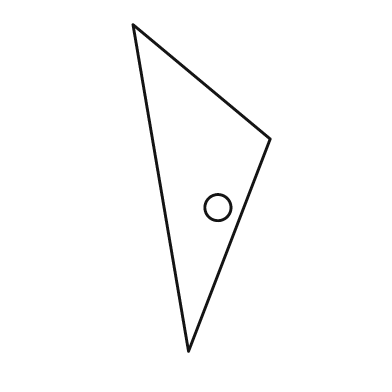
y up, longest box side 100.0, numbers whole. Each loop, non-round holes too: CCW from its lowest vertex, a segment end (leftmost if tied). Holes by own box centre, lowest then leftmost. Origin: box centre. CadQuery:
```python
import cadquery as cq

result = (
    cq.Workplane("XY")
    .moveTo(-4.0, -50.0)
    .lineTo(21.0, 15.0)
    .lineTo(-21.0, 50.0)
    .close()
    .moveTo(5.0, -6.0)
    .circle(4.0)
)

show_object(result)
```